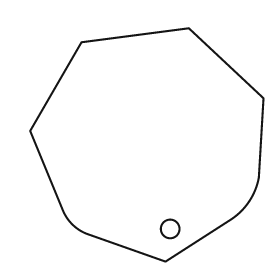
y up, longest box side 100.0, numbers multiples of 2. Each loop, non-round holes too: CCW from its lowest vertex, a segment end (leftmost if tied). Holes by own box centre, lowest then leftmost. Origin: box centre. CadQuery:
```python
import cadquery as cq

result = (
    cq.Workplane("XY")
    .moveTo(8.0, -50.0)
    .lineTo(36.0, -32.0)
    .threePointArc((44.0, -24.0), (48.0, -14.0))
    .lineTo(50.0, 20.0)
    .lineTo(18.0, 50.0)
    .lineTo(-28.0, 44.0)
    .lineTo(-50.0, 6.0)
    .lineTo(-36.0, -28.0)
    .threePointArc((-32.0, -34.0), (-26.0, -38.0))
    .close()
    .moveTo(10.0, -36.0)
    .circle(4.0)
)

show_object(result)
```